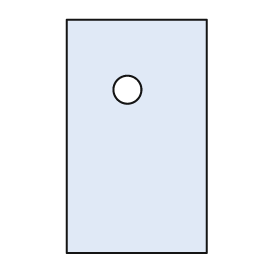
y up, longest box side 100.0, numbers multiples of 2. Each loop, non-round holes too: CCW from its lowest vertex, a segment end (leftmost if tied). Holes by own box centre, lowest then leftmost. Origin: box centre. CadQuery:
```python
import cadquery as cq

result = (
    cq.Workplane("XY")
    .moveTo(-30.0, -50.0)
    .lineTo(30.0, -50.0)
    .lineTo(30.0, 50.0)
    .lineTo(-30.0, 50.0)
    .close()
    .moveTo(-4.0, 20.0)
    .circle(6.0)
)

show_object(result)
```